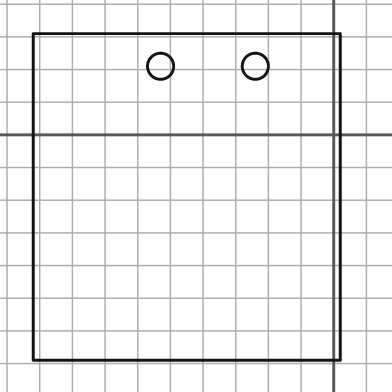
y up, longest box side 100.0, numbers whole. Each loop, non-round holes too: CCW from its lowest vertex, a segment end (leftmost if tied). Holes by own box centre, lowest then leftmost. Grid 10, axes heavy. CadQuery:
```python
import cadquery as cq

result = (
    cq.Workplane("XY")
    .moveTo(-92.0, -69.0)
    .lineTo(2.0, -69.0)
    .lineTo(2.0, 31.0)
    .lineTo(-92.0, 31.0)
    .close()
    .moveTo(-53.0, 21.0)
    .circle(4.0)
    .moveTo(-24.0, 21.0)
    .circle(4.0)
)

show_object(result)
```